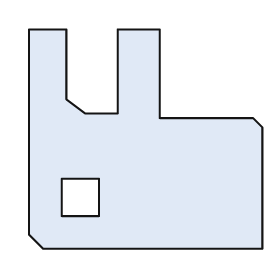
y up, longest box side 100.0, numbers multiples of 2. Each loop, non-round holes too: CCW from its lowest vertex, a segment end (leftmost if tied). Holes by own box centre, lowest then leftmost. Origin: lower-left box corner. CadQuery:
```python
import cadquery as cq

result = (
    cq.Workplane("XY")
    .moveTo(6.0, 0.0)
    .lineTo(100.0, 0.0)
    .lineTo(100.0, 52.0)
    .lineTo(96.0, 56.0)
    .lineTo(56.0, 56.0)
    .lineTo(56.0, 94.0)
    .lineTo(38.0, 94.0)
    .lineTo(38.0, 58.0)
    .lineTo(24.0, 58.0)
    .lineTo(16.0, 64.0)
    .lineTo(16.0, 94.0)
    .lineTo(0.0, 94.0)
    .lineTo(0.0, 6.0)
    .close()
    .moveTo(14.0, 14.0)
    .lineTo(30.0, 14.0)
    .lineTo(30.0, 30.0)
    .lineTo(14.0, 30.0)
    .close()
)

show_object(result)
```